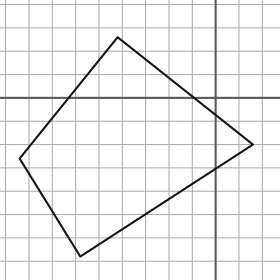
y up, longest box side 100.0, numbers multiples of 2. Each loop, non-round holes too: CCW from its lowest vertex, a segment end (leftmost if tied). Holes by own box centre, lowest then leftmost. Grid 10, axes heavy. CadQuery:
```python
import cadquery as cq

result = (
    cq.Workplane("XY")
    .moveTo(-58.0, -68.0)
    .lineTo(16.0, -20.0)
    .lineTo(-42.0, 26.0)
    .lineTo(-84.0, -26.0)
    .close()
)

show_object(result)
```